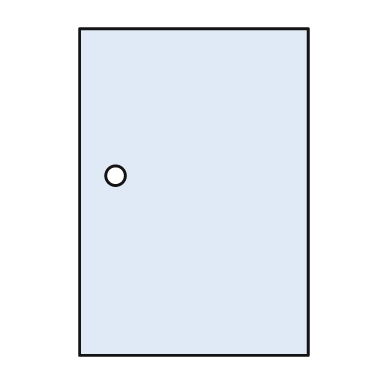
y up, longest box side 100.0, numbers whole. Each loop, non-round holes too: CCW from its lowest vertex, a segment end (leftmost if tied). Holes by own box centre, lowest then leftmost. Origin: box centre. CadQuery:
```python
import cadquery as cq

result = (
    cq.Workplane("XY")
    .moveTo(-35.0, -50.0)
    .lineTo(35.0, -50.0)
    .lineTo(35.0, 50.0)
    .lineTo(-35.0, 50.0)
    .close()
    .moveTo(-24.0, 5.0)
    .circle(3.0)
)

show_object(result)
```